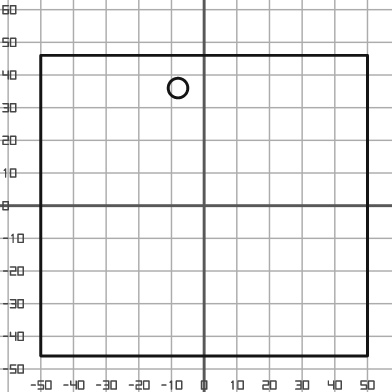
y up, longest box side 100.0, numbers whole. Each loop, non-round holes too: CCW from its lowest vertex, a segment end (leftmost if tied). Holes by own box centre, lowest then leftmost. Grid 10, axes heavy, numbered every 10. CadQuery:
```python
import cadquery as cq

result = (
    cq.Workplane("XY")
    .moveTo(-50.0, -46.0)
    .lineTo(50.0, -46.0)
    .lineTo(50.0, 46.0)
    .lineTo(-50.0, 46.0)
    .close()
    .moveTo(-8.0, 36.0)
    .circle(3.0)
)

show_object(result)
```